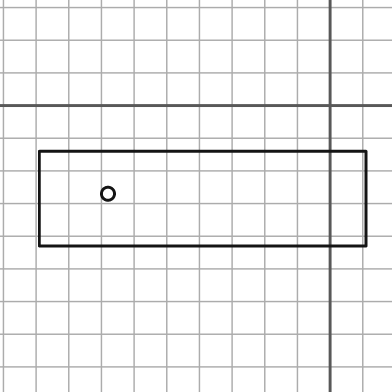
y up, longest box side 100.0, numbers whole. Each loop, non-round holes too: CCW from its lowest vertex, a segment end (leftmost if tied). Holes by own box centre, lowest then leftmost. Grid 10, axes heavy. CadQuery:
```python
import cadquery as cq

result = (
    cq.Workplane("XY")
    .moveTo(-89.0, -43.0)
    .lineTo(11.0, -43.0)
    .lineTo(11.0, -14.0)
    .lineTo(-89.0, -14.0)
    .close()
    .moveTo(-68.0, -27.0)
    .circle(2.0)
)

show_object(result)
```